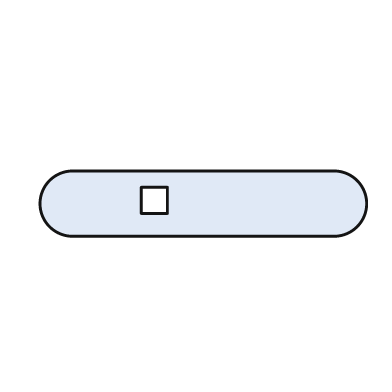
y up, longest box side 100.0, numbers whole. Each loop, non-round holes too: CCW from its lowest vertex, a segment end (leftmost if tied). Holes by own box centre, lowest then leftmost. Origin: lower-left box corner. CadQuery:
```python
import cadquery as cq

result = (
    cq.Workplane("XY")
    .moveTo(10.0, 0.0)
    .lineTo(90.0, 0.0)
    .threePointArc((100.0, 10.0), (90.0, 20.0))
    .lineTo(10.0, 20.0)
    .threePointArc((0.0, 10.0), (10.0, 0.0))
    .close()
    .moveTo(31.0, 7.0)
    .lineTo(39.0, 7.0)
    .lineTo(39.0, 15.0)
    .lineTo(31.0, 15.0)
    .close()
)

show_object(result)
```